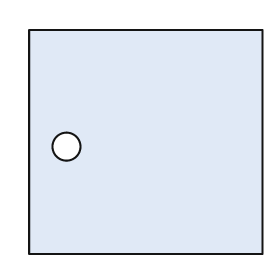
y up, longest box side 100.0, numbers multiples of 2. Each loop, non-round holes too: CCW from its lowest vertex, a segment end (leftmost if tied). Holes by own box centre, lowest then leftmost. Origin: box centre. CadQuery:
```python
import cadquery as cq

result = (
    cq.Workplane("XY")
    .moveTo(-50.0, -48.0)
    .lineTo(50.0, -48.0)
    .lineTo(50.0, 48.0)
    .lineTo(-50.0, 48.0)
    .close()
    .moveTo(-34.0, -2.0)
    .circle(6.0)
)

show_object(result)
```